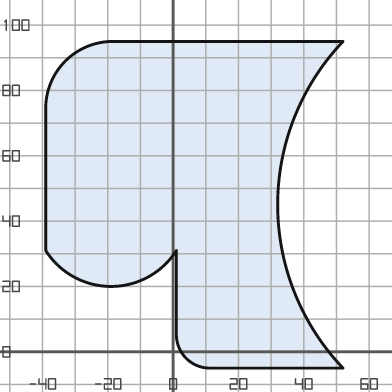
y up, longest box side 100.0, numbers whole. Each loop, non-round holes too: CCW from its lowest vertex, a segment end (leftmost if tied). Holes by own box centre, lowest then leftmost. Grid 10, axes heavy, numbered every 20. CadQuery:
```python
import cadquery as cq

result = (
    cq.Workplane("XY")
    .moveTo(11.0, -5.0)
    .lineTo(52.0, -5.0)
    .threePointArc((32.0, 45.0), (52.0, 95.0))
    .lineTo(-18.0, 95.0)
    .threePointArc((-33.0, 89.0), (-39.0, 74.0))
    .lineTo(-39.0, 31.0)
    .threePointArc((-19.0, 20.0), (1.0, 31.0))
    .lineTo(1.0, 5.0)
    .threePointArc((4.0, -2.0), (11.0, -5.0))
    .close()
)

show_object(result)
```